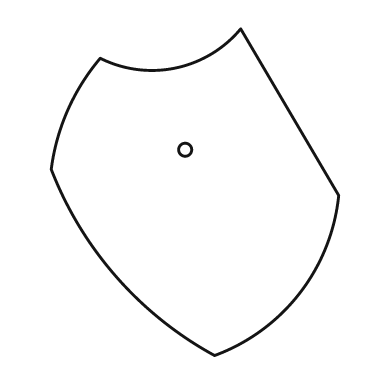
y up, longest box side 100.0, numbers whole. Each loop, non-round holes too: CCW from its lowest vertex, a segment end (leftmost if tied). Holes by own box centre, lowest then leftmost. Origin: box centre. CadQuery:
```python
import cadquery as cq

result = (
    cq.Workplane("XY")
    .moveTo(6.0, -50.0)
    .threePointArc((32.0, -31.0), (44.0, -1.0))
    .lineTo(14.0, 50.0)
    .threePointArc((-6.0, 38.0), (-29.0, 41.0))
    .threePointArc((-39.0, 25.0), (-44.0, 7.0))
    .threePointArc((-24.0, -26.0), (6.0, -50.0))
    .close()
    .moveTo(-3.0, 13.0)
    .circle(2.0)
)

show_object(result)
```